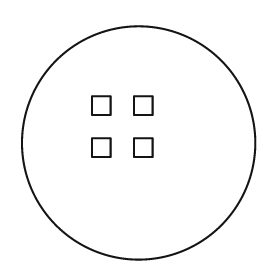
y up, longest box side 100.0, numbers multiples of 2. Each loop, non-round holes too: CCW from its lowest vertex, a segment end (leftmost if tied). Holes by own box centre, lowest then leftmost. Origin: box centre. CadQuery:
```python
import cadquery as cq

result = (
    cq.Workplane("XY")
    .moveTo(0.0, 0.0)
    .circle(50.0)
    .moveTo(-20.0, -6.0)
    .lineTo(-12.0, -6.0)
    .lineTo(-12.0, 2.0)
    .lineTo(-20.0, 2.0)
    .close()
    .moveTo(-2.0, -6.0)
    .lineTo(6.0, -6.0)
    .lineTo(6.0, 2.0)
    .lineTo(-2.0, 2.0)
    .close()
    .moveTo(-20.0, 12.0)
    .lineTo(-12.0, 12.0)
    .lineTo(-12.0, 20.0)
    .lineTo(-20.0, 20.0)
    .close()
    .moveTo(-2.0, 12.0)
    .lineTo(6.0, 12.0)
    .lineTo(6.0, 20.0)
    .lineTo(-2.0, 20.0)
    .close()
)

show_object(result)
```